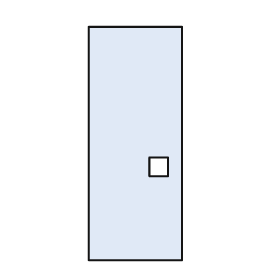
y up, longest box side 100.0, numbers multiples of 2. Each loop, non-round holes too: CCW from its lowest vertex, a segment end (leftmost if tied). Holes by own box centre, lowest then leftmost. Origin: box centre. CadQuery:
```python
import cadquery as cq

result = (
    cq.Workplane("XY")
    .moveTo(-20.0, -50.0)
    .lineTo(20.0, -50.0)
    .lineTo(20.0, 50.0)
    .lineTo(-20.0, 50.0)
    .close()
    .moveTo(6.0, -14.0)
    .lineTo(14.0, -14.0)
    .lineTo(14.0, -6.0)
    .lineTo(6.0, -6.0)
    .close()
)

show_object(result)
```